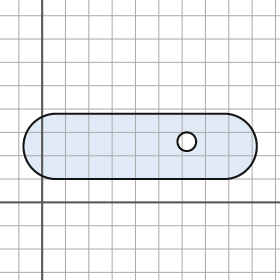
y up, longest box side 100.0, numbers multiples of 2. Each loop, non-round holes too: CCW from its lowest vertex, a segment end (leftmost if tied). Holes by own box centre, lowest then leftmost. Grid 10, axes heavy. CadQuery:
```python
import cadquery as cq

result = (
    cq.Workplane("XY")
    .moveTo(6.0, 10.0)
    .lineTo(78.0, 10.0)
    .threePointArc((92.0, 24.0), (78.0, 38.0))
    .lineTo(6.0, 38.0)
    .threePointArc((-8.0, 24.0), (6.0, 10.0))
    .close()
    .moveTo(62.0, 26.0)
    .circle(4.0)
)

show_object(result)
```